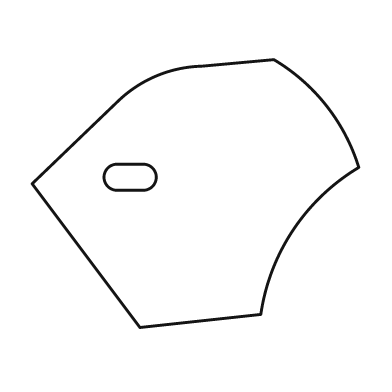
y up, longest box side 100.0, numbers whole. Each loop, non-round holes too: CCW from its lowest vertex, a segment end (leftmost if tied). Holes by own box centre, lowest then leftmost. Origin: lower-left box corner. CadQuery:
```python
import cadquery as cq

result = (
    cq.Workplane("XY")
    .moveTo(33.0, 0.0)
    .lineTo(70.0, 4.0)
    .threePointArc((80.0, 30.0), (100.0, 49.0))
    .threePointArc((90.0, 68.0), (74.0, 82.0))
    .lineTo(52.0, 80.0)
    .threePointArc((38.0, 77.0), (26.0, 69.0))
    .lineTo(0.0, 44.0)
    .close()
    .moveTo(26.0, 42.0)
    .lineTo(34.0, 42.0)
    .threePointArc((38.0, 46.0), (34.0, 50.0))
    .lineTo(26.0, 50.0)
    .threePointArc((22.0, 46.0), (26.0, 42.0))
    .close()
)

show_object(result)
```